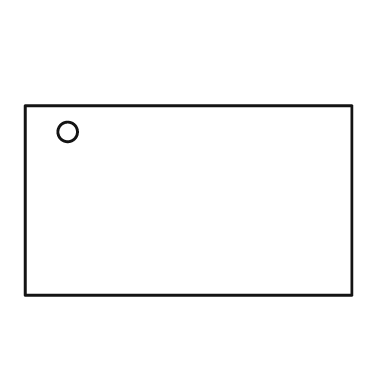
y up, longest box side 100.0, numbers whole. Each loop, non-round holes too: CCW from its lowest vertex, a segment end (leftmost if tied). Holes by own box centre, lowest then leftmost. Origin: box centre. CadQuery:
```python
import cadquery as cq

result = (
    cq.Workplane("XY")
    .moveTo(-50.0, -29.0)
    .lineTo(50.0, -29.0)
    .lineTo(50.0, 29.0)
    .lineTo(-50.0, 29.0)
    .close()
    .moveTo(-37.0, 21.0)
    .circle(3.0)
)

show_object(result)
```